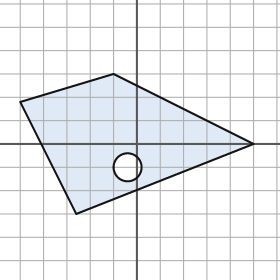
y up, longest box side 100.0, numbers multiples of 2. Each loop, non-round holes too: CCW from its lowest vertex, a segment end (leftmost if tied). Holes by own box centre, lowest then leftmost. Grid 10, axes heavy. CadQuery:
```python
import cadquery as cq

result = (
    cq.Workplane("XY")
    .moveTo(-26.0, -30.0)
    .lineTo(50.0, 0.0)
    .lineTo(-10.0, 30.0)
    .lineTo(-50.0, 18.0)
    .close()
    .moveTo(-4.0, -10.0)
    .circle(6.0)
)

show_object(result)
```